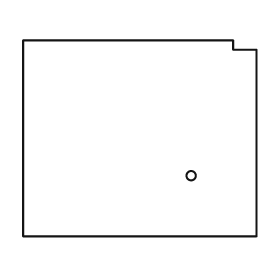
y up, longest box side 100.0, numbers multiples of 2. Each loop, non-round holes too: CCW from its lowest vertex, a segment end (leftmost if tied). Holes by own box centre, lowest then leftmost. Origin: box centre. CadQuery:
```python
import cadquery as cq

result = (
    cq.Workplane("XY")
    .moveTo(-50.0, -42.0)
    .lineTo(50.0, -42.0)
    .lineTo(50.0, 38.0)
    .lineTo(40.0, 38.0)
    .lineTo(40.0, 42.0)
    .lineTo(-50.0, 42.0)
    .close()
    .moveTo(22.0, -16.0)
    .circle(2.0)
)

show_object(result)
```